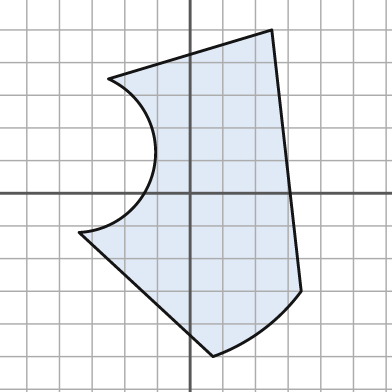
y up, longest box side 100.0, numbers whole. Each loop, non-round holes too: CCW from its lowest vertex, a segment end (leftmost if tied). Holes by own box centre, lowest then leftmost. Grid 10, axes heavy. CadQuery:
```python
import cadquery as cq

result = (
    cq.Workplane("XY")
    .moveTo(7.0, -50.0)
    .threePointArc((22.0, -42.0), (34.0, -30.0))
    .lineTo(25.0, 50.0)
    .lineTo(-25.0, 35.0)
    .threePointArc((-11.0, 8.0), (-34.0, -12.0))
    .close()
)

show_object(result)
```